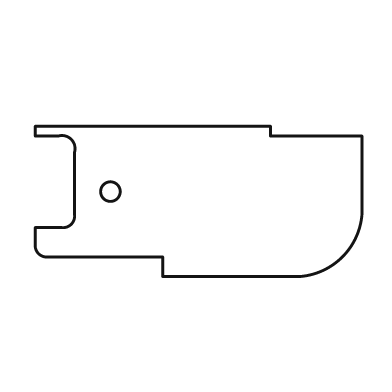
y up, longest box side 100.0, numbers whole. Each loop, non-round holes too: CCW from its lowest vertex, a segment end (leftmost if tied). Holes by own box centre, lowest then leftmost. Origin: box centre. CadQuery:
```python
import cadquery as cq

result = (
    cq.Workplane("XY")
    .moveTo(-11.0, -23.0)
    .lineTo(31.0, -23.0)
    .threePointArc((44.0, -17.0), (50.0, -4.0))
    .lineTo(50.0, 20.0)
    .lineTo(22.0, 20.0)
    .lineTo(22.0, 23.0)
    .lineTo(-50.0, 23.0)
    .lineTo(-50.0, 20.0)
    .lineTo(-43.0, 20.0)
    .threePointArc((-39.0, 19.0), (-38.0, 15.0))
    .lineTo(-38.0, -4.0)
    .threePointArc((-39.0, -7.0), (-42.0, -8.0))
    .lineTo(-50.0, -8.0)
    .lineTo(-50.0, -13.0)
    .threePointArc((-49.0, -16.0), (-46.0, -17.0))
    .lineTo(-11.0, -17.0)
    .close()
    .moveTo(-27.0, 3.0)
    .circle(3.0)
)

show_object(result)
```